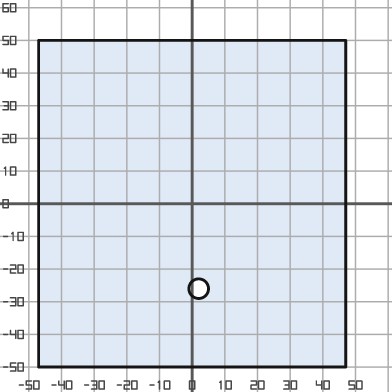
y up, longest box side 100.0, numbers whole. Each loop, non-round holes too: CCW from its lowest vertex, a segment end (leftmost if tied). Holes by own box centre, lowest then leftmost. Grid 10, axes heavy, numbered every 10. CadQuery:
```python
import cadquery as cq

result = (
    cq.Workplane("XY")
    .moveTo(-47.0, -50.0)
    .lineTo(47.0, -50.0)
    .lineTo(47.0, 50.0)
    .lineTo(-47.0, 50.0)
    .close()
    .moveTo(2.0, -26.0)
    .circle(3.0)
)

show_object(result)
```